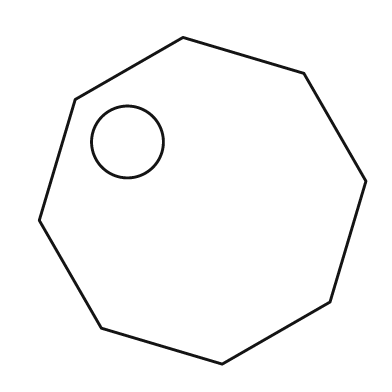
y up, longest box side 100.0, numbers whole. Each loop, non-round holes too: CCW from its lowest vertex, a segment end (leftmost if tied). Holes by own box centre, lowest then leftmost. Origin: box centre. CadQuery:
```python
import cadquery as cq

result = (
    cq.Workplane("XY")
    .moveTo(6.0, -50.0)
    .lineTo(39.0, -31.0)
    .lineTo(50.0, 6.0)
    .lineTo(31.0, 39.0)
    .lineTo(-6.0, 50.0)
    .lineTo(-39.0, 31.0)
    .lineTo(-50.0, -6.0)
    .lineTo(-31.0, -39.0)
    .close()
    .moveTo(-23.0, 18.0)
    .circle(11.0)
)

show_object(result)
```